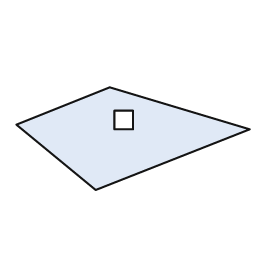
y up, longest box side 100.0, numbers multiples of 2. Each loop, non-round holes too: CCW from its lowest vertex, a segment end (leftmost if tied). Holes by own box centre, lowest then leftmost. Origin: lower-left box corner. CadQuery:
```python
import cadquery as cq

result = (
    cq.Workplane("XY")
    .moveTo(34.0, 0.0)
    .lineTo(100.0, 26.0)
    .lineTo(40.0, 44.0)
    .lineTo(0.0, 28.0)
    .close()
    .moveTo(42.0, 26.0)
    .lineTo(50.0, 26.0)
    .lineTo(50.0, 34.0)
    .lineTo(42.0, 34.0)
    .close()
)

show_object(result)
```